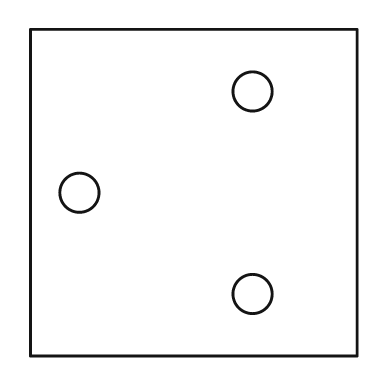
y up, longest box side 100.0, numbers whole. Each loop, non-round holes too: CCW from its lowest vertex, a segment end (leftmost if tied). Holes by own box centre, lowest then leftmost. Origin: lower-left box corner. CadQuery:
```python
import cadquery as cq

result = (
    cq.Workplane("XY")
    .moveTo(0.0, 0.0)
    .lineTo(100.0, 0.0)
    .lineTo(100.0, 100.0)
    .lineTo(0.0, 100.0)
    .close()
    .moveTo(68.0, 19.0)
    .circle(6.0)
    .moveTo(15.0, 50.0)
    .circle(6.0)
    .moveTo(68.0, 81.0)
    .circle(6.0)
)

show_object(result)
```